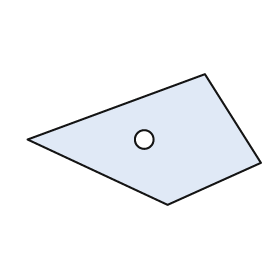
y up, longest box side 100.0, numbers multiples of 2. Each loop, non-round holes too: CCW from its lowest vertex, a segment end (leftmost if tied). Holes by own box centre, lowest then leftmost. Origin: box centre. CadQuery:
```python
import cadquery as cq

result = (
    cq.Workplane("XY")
    .moveTo(10.0, -28.0)
    .lineTo(50.0, -10.0)
    .lineTo(26.0, 28.0)
    .lineTo(-50.0, 0.0)
    .close()
    .moveTo(0.0, 0.0)
    .circle(4.0)
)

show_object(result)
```